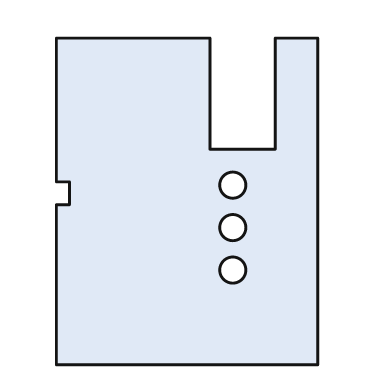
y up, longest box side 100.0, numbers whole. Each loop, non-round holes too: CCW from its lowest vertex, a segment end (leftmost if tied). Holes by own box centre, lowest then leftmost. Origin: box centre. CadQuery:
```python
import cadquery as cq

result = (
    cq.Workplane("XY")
    .moveTo(-40.0, -50.0)
    .lineTo(40.0, -50.0)
    .lineTo(40.0, 50.0)
    .lineTo(27.0, 50.0)
    .lineTo(27.0, 16.0)
    .lineTo(7.0, 16.0)
    .lineTo(7.0, 50.0)
    .lineTo(-40.0, 50.0)
    .lineTo(-40.0, 6.0)
    .lineTo(-36.0, 6.0)
    .lineTo(-36.0, -1.0)
    .lineTo(-40.0, -1.0)
    .close()
    .moveTo(14.0, -21.0)
    .circle(4.0)
    .moveTo(14.0, -8.0)
    .circle(4.0)
    .moveTo(14.0, 5.0)
    .circle(4.0)
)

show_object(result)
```